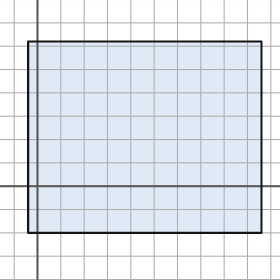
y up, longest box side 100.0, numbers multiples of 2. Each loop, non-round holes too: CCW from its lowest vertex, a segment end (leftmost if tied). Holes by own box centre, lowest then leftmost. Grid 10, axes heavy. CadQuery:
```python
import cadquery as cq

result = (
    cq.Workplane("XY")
    .moveTo(-4.0, -20.0)
    .lineTo(96.0, -20.0)
    .lineTo(96.0, 62.0)
    .lineTo(-4.0, 62.0)
    .close()
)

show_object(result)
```